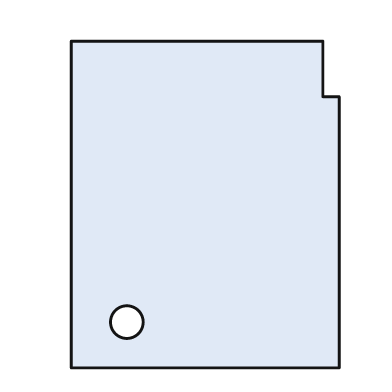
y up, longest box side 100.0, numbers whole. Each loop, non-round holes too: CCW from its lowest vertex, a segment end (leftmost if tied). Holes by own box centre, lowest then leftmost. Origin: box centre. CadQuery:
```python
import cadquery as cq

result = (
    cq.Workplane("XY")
    .moveTo(-41.0, -50.0)
    .lineTo(41.0, -50.0)
    .lineTo(41.0, 33.0)
    .lineTo(36.0, 33.0)
    .lineTo(36.0, 50.0)
    .lineTo(-41.0, 50.0)
    .close()
    .moveTo(-24.0, -36.0)
    .circle(5.0)
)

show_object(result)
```